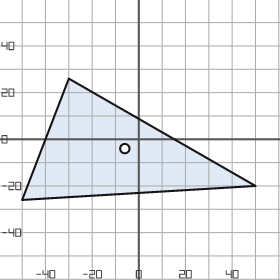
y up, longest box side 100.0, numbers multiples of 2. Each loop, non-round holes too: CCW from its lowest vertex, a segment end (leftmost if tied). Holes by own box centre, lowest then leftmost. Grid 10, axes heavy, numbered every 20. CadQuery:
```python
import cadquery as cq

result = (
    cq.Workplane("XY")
    .moveTo(-50.0, -26.0)
    .lineTo(50.0, -20.0)
    .lineTo(-30.0, 26.0)
    .close()
    .moveTo(-6.0, -4.0)
    .circle(2.0)
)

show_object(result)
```